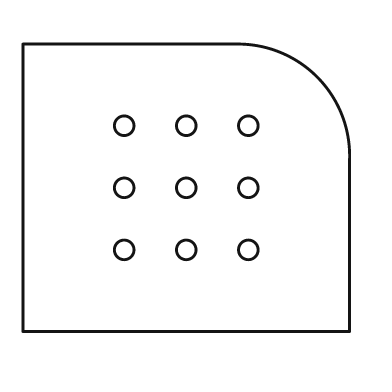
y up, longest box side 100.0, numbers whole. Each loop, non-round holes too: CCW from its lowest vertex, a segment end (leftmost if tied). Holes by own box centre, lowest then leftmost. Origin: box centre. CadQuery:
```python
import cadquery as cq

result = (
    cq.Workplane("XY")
    .moveTo(-50.0, -44.0)
    .lineTo(50.0, -44.0)
    .lineTo(50.0, 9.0)
    .threePointArc((40.0, 34.0), (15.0, 44.0))
    .lineTo(-50.0, 44.0)
    .close()
    .moveTo(-19.0, -19.0)
    .circle(3.0)
    .moveTo(0.0, -19.0)
    .circle(3.0)
    .moveTo(19.0, -19.0)
    .circle(3.0)
    .moveTo(-19.0, 0.0)
    .circle(3.0)
    .moveTo(0.0, 0.0)
    .circle(3.0)
    .moveTo(19.0, 0.0)
    .circle(3.0)
    .moveTo(-19.0, 19.0)
    .circle(3.0)
    .moveTo(0.0, 19.0)
    .circle(3.0)
    .moveTo(19.0, 19.0)
    .circle(3.0)
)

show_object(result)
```